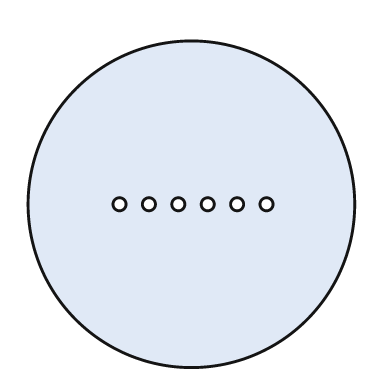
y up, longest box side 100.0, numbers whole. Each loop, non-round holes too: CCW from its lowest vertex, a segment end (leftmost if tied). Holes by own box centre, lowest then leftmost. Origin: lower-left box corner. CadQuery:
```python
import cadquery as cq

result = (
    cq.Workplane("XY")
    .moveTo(50.0, 50.0)
    .circle(50.0)
    .moveTo(28.0, 50.0)
    .circle(2.0)
    .moveTo(37.0, 50.0)
    .circle(2.0)
    .moveTo(46.0, 50.0)
    .circle(2.0)
    .moveTo(55.0, 50.0)
    .circle(2.0)
    .moveTo(64.0, 50.0)
    .circle(2.0)
    .moveTo(73.0, 50.0)
    .circle(2.0)
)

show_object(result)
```